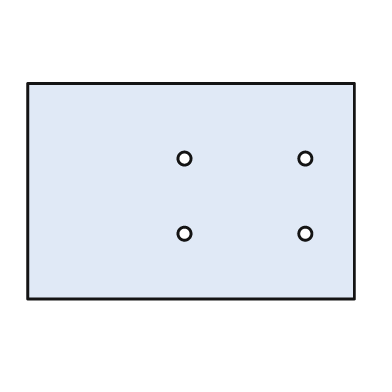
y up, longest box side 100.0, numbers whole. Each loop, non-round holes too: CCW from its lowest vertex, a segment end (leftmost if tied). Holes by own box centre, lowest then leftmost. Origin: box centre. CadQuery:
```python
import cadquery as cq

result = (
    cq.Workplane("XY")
    .moveTo(-50.0, -33.0)
    .lineTo(50.0, -33.0)
    .lineTo(50.0, 33.0)
    .lineTo(-50.0, 33.0)
    .close()
    .moveTo(-2.0, -13.0)
    .circle(2.0)
    .moveTo(35.0, -13.0)
    .circle(2.0)
    .moveTo(-2.0, 10.0)
    .circle(2.0)
    .moveTo(35.0, 10.0)
    .circle(2.0)
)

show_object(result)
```